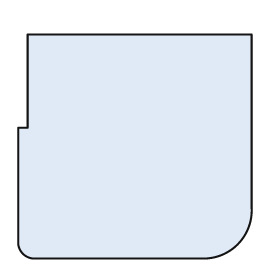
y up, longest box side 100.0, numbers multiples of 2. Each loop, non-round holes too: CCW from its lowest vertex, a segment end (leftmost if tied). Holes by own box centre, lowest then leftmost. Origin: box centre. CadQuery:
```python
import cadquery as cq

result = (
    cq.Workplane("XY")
    .moveTo(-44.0, -48.0)
    .lineTo(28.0, -48.0)
    .threePointArc((44.0, -42.0), (50.0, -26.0))
    .lineTo(50.0, 48.0)
    .lineTo(-46.0, 48.0)
    .lineTo(-46.0, 8.0)
    .lineTo(-50.0, 8.0)
    .lineTo(-50.0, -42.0)
    .threePointArc((-48.0, -46.0), (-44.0, -48.0))
    .close()
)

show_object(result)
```